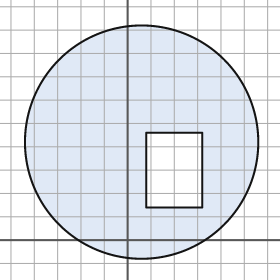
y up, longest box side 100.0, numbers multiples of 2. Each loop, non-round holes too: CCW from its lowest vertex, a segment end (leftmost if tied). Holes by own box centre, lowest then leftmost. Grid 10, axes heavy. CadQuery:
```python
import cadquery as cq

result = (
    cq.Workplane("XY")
    .moveTo(6.0, 42.0)
    .circle(50.0)
    .moveTo(8.0, 14.0)
    .lineTo(32.0, 14.0)
    .lineTo(32.0, 46.0)
    .lineTo(8.0, 46.0)
    .close()
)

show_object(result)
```